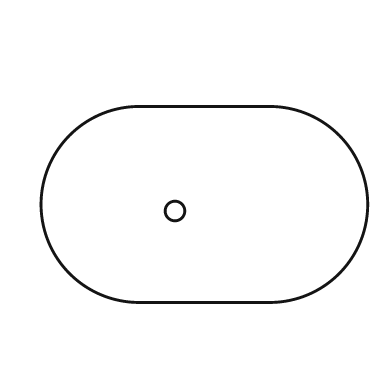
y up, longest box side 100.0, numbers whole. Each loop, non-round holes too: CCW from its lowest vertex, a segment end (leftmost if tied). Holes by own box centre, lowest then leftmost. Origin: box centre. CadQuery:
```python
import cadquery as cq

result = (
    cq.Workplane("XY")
    .moveTo(-20.0, -30.0)
    .lineTo(20.0, -30.0)
    .threePointArc((50.0, 0.0), (20.0, 30.0))
    .lineTo(-20.0, 30.0)
    .threePointArc((-50.0, 0.0), (-20.0, -30.0))
    .close()
    .moveTo(-9.0, -2.0)
    .circle(3.0)
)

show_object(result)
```